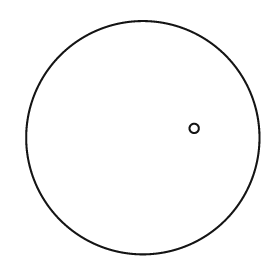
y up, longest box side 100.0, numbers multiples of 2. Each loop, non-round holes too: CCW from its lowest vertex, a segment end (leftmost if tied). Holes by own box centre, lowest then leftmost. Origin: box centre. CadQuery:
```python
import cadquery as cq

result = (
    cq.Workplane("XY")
    .moveTo(0.0, 0.0)
    .circle(50.0)
    .moveTo(22.0, 4.0)
    .circle(2.0)
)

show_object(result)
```